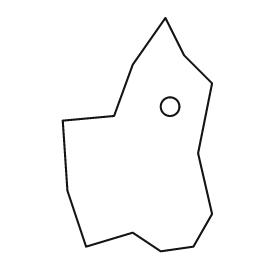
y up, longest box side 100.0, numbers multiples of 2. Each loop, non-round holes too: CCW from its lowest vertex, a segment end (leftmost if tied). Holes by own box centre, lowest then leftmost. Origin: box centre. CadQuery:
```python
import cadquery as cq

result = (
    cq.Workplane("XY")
    .moveTo(10.0, -50.0)
    .lineTo(24.0, -48.0)
    .lineTo(32.0, -34.0)
    .lineTo(26.0, -8.0)
    .lineTo(32.0, 22.0)
    .lineTo(20.0, 34.0)
    .lineTo(12.0, 50.0)
    .lineTo(-2.0, 30.0)
    .lineTo(-10.0, 8.0)
    .lineTo(-32.0, 6.0)
    .lineTo(-30.0, -24.0)
    .lineTo(-22.0, -48.0)
    .lineTo(-2.0, -42.0)
    .close()
    .moveTo(14.0, 12.0)
    .circle(4.0)
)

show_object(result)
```